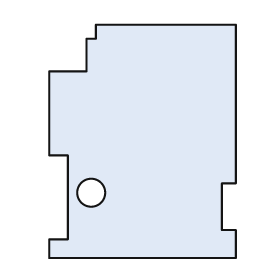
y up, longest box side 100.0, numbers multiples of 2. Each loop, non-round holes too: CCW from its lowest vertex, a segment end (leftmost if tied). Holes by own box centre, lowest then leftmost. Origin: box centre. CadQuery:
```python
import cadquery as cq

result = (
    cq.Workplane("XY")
    .moveTo(-40.0, -50.0)
    .lineTo(40.0, -50.0)
    .lineTo(40.0, -38.0)
    .lineTo(34.0, -38.0)
    .lineTo(34.0, -18.0)
    .lineTo(40.0, -18.0)
    .lineTo(40.0, 50.0)
    .lineTo(-20.0, 50.0)
    .lineTo(-20.0, 44.0)
    .lineTo(-24.0, 44.0)
    .lineTo(-24.0, 30.0)
    .lineTo(-40.0, 30.0)
    .lineTo(-40.0, -6.0)
    .lineTo(-32.0, -6.0)
    .lineTo(-32.0, -42.0)
    .lineTo(-40.0, -42.0)
    .close()
    .moveTo(-22.0, -22.0)
    .circle(6.0)
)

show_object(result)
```